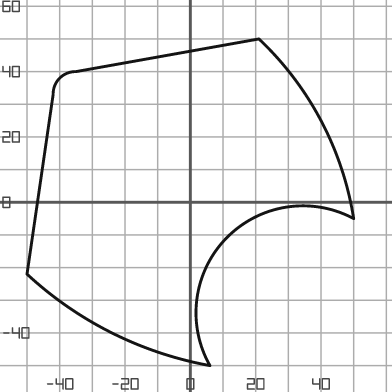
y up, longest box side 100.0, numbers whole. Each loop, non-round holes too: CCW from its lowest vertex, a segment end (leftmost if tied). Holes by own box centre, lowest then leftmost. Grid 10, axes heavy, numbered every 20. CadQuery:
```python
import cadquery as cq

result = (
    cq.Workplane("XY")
    .moveTo(6.0, -50.0)
    .threePointArc((11.0, -11.0), (50.0, -5.0))
    .threePointArc((40.0, 25.0), (21.0, 50.0))
    .lineTo(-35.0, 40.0)
    .threePointArc((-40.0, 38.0), (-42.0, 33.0))
    .lineTo(-50.0, -22.0)
    .threePointArc((-24.0, -40.0), (6.0, -50.0))
    .close()
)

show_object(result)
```